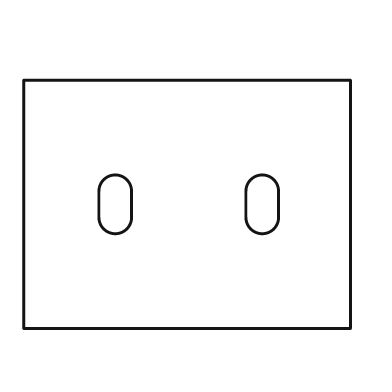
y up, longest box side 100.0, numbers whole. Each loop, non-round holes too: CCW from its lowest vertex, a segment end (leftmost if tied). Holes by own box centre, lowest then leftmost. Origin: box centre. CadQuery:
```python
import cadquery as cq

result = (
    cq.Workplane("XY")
    .moveTo(-50.0, -38.0)
    .lineTo(50.0, -38.0)
    .lineTo(50.0, 38.0)
    .lineTo(-50.0, 38.0)
    .close()
    .moveTo(-27.0, -4.0)
    .threePointArc((-22.0, -9.0), (-17.0, -4.0))
    .lineTo(-17.0, 4.0)
    .threePointArc((-22.0, 9.0), (-27.0, 4.0))
    .close()
    .moveTo(18.0, -4.0)
    .threePointArc((23.0, -9.0), (28.0, -4.0))
    .lineTo(28.0, 4.0)
    .threePointArc((23.0, 9.0), (18.0, 4.0))
    .close()
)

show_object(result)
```